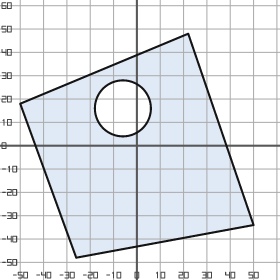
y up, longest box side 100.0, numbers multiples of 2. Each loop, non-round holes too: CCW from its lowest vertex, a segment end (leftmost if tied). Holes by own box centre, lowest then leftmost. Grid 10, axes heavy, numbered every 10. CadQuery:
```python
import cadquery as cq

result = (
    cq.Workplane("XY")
    .moveTo(-26.0, -48.0)
    .lineTo(50.0, -34.0)
    .lineTo(22.0, 48.0)
    .lineTo(-50.0, 18.0)
    .close()
    .moveTo(-6.0, 16.0)
    .circle(12.0)
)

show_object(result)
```